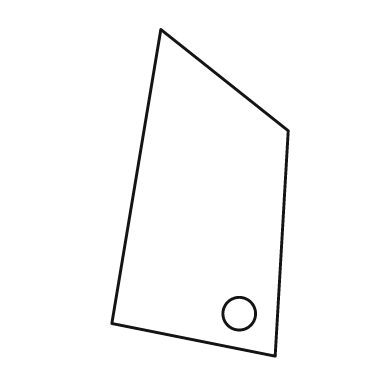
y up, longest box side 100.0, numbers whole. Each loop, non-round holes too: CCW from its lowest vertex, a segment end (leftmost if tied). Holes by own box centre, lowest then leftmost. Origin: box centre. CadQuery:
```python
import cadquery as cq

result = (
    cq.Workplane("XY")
    .moveTo(23.0, -50.0)
    .lineTo(27.0, 19.0)
    .lineTo(-12.0, 50.0)
    .lineTo(-27.0, -40.0)
    .close()
    .moveTo(12.0, -37.0)
    .circle(5.0)
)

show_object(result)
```